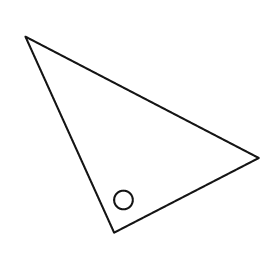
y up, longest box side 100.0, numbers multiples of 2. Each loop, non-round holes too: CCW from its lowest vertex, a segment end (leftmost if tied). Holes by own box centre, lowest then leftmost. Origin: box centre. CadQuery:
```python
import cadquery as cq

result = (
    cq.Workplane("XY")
    .moveTo(-12.0, -42.0)
    .lineTo(50.0, -10.0)
    .lineTo(-50.0, 42.0)
    .close()
    .moveTo(-8.0, -28.0)
    .circle(4.0)
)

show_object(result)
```